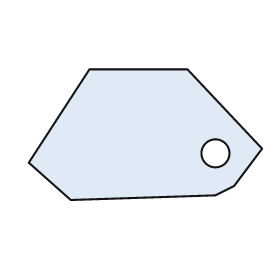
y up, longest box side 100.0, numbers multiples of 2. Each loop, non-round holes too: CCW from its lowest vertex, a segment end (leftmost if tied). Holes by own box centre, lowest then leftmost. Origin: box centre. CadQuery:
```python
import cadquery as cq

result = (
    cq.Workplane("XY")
    .moveTo(-32.0, -28.0)
    .lineTo(30.0, -26.0)
    .lineTo(38.0, -22.0)
    .lineTo(50.0, -6.0)
    .lineTo(18.0, 28.0)
    .lineTo(-24.0, 28.0)
    .lineTo(-50.0, -12.0)
    .close()
    .moveTo(30.0, -8.0)
    .circle(6.0)
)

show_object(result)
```